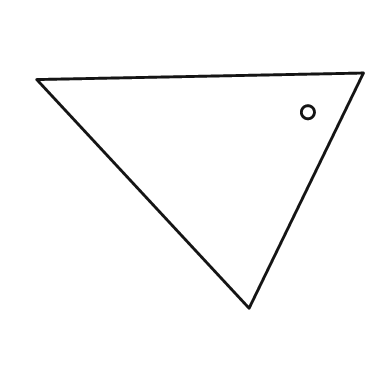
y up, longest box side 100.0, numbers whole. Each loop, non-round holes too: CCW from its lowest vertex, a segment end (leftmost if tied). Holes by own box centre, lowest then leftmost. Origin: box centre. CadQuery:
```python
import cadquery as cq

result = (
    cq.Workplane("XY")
    .moveTo(15.0, -36.0)
    .lineTo(50.0, 36.0)
    .lineTo(-50.0, 34.0)
    .close()
    .moveTo(33.0, 24.0)
    .circle(2.0)
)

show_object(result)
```